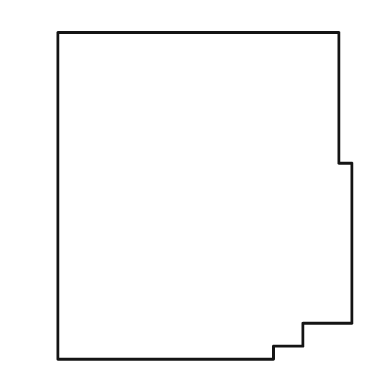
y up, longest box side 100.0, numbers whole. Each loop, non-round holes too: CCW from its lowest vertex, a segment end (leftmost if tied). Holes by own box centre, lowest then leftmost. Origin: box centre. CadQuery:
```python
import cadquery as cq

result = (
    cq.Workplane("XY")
    .moveTo(-45.0, -50.0)
    .lineTo(21.0, -50.0)
    .lineTo(21.0, -46.0)
    .lineTo(30.0, -46.0)
    .lineTo(30.0, -39.0)
    .lineTo(45.0, -39.0)
    .lineTo(45.0, 10.0)
    .lineTo(41.0, 10.0)
    .lineTo(41.0, 50.0)
    .lineTo(-45.0, 50.0)
    .close()
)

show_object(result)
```